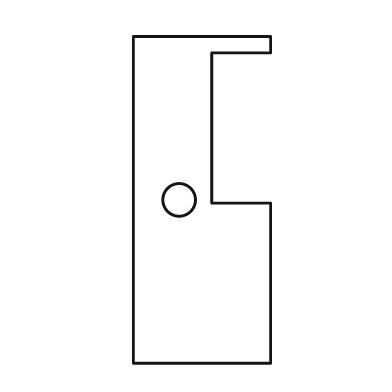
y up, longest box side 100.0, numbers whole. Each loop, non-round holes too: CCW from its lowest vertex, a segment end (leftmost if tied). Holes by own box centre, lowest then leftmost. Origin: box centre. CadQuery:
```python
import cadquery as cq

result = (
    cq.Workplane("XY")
    .moveTo(-21.0, -50.0)
    .lineTo(21.0, -50.0)
    .lineTo(21.0, -1.0)
    .lineTo(3.0, -1.0)
    .lineTo(3.0, 45.0)
    .lineTo(21.0, 45.0)
    .lineTo(21.0, 50.0)
    .lineTo(-21.0, 50.0)
    .close()
    .moveTo(-7.0, 0.0)
    .circle(5.0)
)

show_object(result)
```